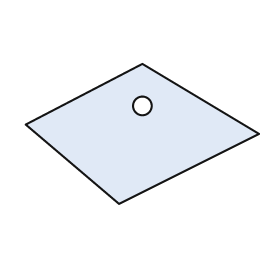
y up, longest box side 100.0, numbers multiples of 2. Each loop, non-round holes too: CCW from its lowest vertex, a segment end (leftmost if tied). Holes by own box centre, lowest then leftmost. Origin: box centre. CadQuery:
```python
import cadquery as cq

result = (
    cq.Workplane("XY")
    .moveTo(-10.0, -30.0)
    .lineTo(50.0, 0.0)
    .lineTo(0.0, 30.0)
    .lineTo(-50.0, 4.0)
    .close()
    .moveTo(0.0, 12.0)
    .circle(4.0)
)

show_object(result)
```